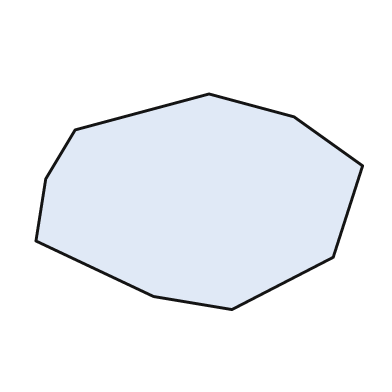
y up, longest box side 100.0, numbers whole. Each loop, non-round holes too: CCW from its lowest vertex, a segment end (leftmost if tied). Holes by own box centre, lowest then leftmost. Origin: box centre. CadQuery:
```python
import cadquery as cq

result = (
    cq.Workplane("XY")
    .moveTo(10.0, -33.0)
    .lineTo(41.0, -17.0)
    .lineTo(50.0, 11.0)
    .lineTo(29.0, 26.0)
    .lineTo(3.0, 33.0)
    .lineTo(-38.0, 22.0)
    .lineTo(-47.0, 7.0)
    .lineTo(-50.0, -12.0)
    .lineTo(-14.0, -29.0)
    .close()
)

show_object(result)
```